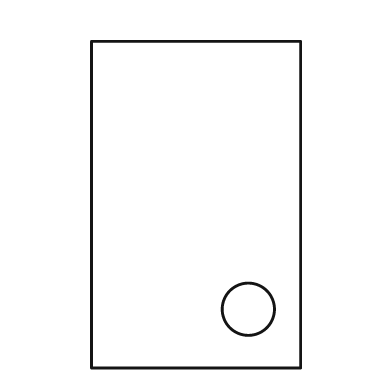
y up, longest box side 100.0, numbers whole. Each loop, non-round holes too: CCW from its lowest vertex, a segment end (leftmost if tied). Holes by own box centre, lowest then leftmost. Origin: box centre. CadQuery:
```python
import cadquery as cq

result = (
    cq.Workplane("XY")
    .moveTo(-32.0, -50.0)
    .lineTo(32.0, -50.0)
    .lineTo(32.0, 50.0)
    .lineTo(-32.0, 50.0)
    .close()
    .moveTo(16.0, -32.0)
    .circle(8.0)
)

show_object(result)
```